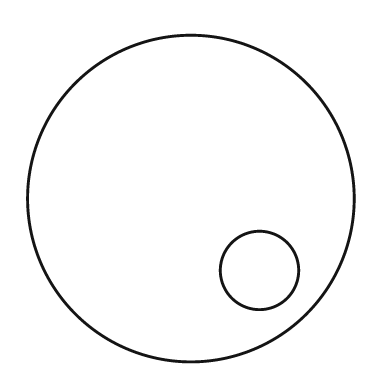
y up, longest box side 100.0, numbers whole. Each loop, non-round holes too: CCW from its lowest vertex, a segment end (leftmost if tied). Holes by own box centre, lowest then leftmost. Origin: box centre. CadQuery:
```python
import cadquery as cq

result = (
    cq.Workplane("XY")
    .moveTo(0.0, 0.0)
    .circle(50.0)
    .moveTo(21.0, -22.0)
    .circle(12.0)
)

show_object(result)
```